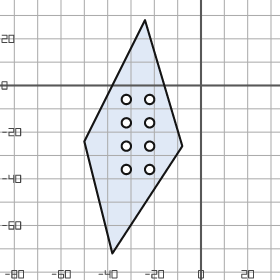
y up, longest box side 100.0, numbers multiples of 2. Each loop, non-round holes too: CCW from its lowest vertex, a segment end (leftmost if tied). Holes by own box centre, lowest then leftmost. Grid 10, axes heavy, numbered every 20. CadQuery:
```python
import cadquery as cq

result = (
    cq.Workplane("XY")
    .moveTo(-38.0, -72.0)
    .lineTo(-8.0, -26.0)
    .lineTo(-24.0, 28.0)
    .lineTo(-50.0, -24.0)
    .close()
    .moveTo(-32.0, -36.0)
    .circle(2.0)
    .moveTo(-22.0, -36.0)
    .circle(2.0)
    .moveTo(-32.0, -26.0)
    .circle(2.0)
    .moveTo(-22.0, -26.0)
    .circle(2.0)
    .moveTo(-32.0, -16.0)
    .circle(2.0)
    .moveTo(-22.0, -16.0)
    .circle(2.0)
    .moveTo(-32.0, -6.0)
    .circle(2.0)
    .moveTo(-22.0, -6.0)
    .circle(2.0)
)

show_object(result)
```